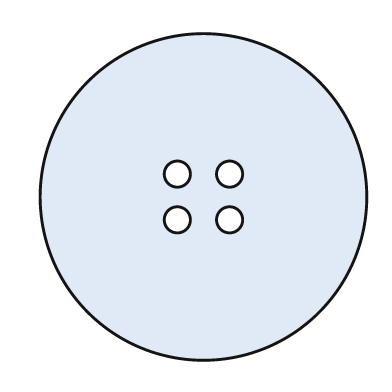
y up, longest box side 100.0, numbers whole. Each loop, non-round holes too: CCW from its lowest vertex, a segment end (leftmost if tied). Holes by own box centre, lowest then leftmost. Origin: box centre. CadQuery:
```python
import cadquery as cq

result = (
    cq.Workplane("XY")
    .moveTo(0.0, 0.0)
    .circle(50.0)
    .moveTo(-8.0, -7.0)
    .circle(4.0)
    .moveTo(8.0, -7.0)
    .circle(4.0)
    .moveTo(-8.0, 7.0)
    .circle(4.0)
    .moveTo(8.0, 7.0)
    .circle(4.0)
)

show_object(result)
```